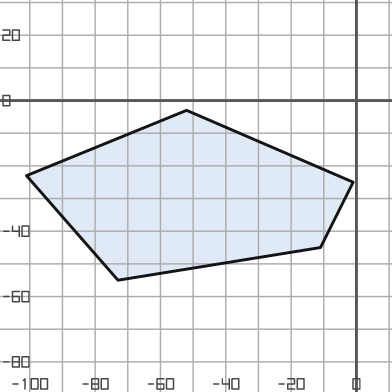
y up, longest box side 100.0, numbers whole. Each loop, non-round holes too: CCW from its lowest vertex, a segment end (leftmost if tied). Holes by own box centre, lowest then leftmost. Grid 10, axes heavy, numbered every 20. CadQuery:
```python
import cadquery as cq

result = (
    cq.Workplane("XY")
    .moveTo(-73.0, -55.0)
    .lineTo(-11.0, -45.0)
    .lineTo(-1.0, -25.0)
    .lineTo(-52.0, -3.0)
    .lineTo(-101.0, -23.0)
    .close()
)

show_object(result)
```